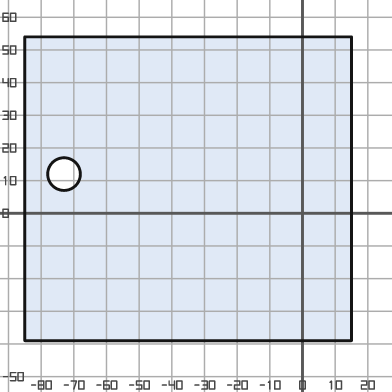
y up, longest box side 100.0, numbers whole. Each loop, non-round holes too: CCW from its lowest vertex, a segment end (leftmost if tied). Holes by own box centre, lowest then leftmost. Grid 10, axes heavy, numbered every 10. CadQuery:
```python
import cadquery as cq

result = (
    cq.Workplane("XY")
    .moveTo(-85.0, -39.0)
    .lineTo(15.0, -39.0)
    .lineTo(15.0, 54.0)
    .lineTo(-85.0, 54.0)
    .close()
    .moveTo(-73.0, 12.0)
    .circle(5.0)
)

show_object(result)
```